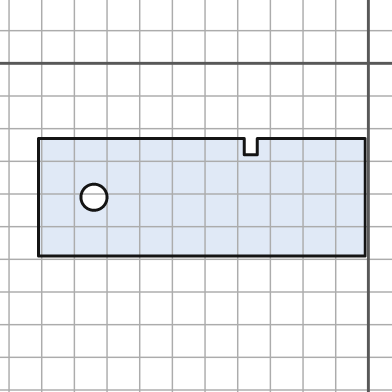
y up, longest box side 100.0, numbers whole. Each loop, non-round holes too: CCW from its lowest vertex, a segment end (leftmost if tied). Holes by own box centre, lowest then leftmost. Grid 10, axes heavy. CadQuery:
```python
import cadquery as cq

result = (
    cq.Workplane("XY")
    .moveTo(-101.0, -59.0)
    .lineTo(-1.0, -59.0)
    .lineTo(-1.0, -23.0)
    .lineTo(-34.0, -23.0)
    .lineTo(-34.0, -28.0)
    .lineTo(-38.0, -28.0)
    .lineTo(-38.0, -23.0)
    .lineTo(-101.0, -23.0)
    .close()
    .moveTo(-84.0, -41.0)
    .circle(4.0)
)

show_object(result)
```